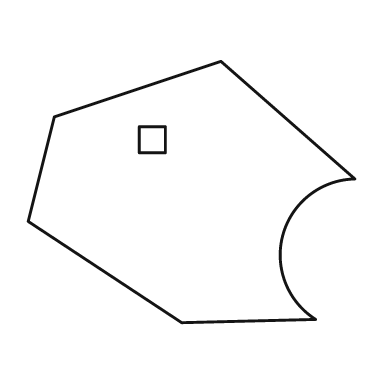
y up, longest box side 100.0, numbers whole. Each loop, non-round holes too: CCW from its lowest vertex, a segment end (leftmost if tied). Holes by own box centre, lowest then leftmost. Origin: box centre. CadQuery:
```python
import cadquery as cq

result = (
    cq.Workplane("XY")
    .moveTo(-3.0, -40.0)
    .lineTo(38.0, -39.0)
    .threePointArc((28.0, -13.0), (50.0, 4.0))
    .lineTo(9.0, 40.0)
    .lineTo(-42.0, 23.0)
    .lineTo(-50.0, -9.0)
    .close()
    .moveTo(-16.0, 12.0)
    .lineTo(-8.0, 12.0)
    .lineTo(-8.0, 20.0)
    .lineTo(-16.0, 20.0)
    .close()
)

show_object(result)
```